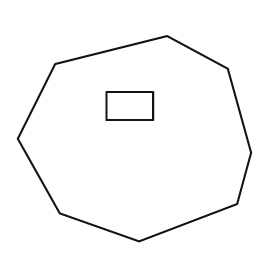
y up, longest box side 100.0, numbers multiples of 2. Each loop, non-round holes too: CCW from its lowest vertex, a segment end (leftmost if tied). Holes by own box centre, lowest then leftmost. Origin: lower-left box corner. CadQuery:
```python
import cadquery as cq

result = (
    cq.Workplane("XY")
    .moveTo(52.0, 0.0)
    .lineTo(94.0, 16.0)
    .lineTo(100.0, 38.0)
    .lineTo(90.0, 74.0)
    .lineTo(64.0, 88.0)
    .lineTo(16.0, 76.0)
    .lineTo(0.0, 44.0)
    .lineTo(18.0, 12.0)
    .close()
    .moveTo(38.0, 52.0)
    .lineTo(58.0, 52.0)
    .lineTo(58.0, 64.0)
    .lineTo(38.0, 64.0)
    .close()
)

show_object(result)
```